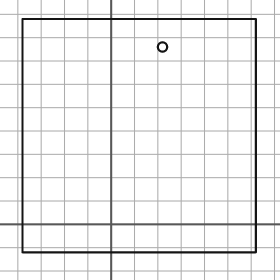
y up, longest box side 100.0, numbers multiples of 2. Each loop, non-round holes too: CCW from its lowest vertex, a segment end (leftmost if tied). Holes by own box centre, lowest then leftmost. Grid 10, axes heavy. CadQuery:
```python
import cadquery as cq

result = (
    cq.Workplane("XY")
    .moveTo(-38.0, -12.0)
    .lineTo(62.0, -12.0)
    .lineTo(62.0, 88.0)
    .lineTo(-38.0, 88.0)
    .close()
    .moveTo(22.0, 76.0)
    .circle(2.0)
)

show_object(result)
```